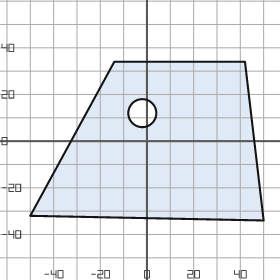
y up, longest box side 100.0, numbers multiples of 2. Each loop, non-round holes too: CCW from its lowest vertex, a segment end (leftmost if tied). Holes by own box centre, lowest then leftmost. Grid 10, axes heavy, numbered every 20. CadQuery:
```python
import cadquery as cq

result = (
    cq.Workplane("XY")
    .moveTo(50.0, -34.0)
    .lineTo(42.0, 34.0)
    .lineTo(-14.0, 34.0)
    .lineTo(-50.0, -32.0)
    .close()
    .moveTo(-2.0, 12.0)
    .circle(6.0)
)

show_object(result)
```